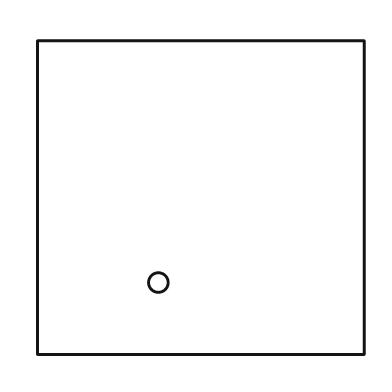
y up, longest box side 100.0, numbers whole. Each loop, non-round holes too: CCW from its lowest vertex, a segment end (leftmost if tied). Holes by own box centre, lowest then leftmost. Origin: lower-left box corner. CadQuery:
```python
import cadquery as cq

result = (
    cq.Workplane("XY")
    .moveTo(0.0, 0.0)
    .lineTo(100.0, 0.0)
    .lineTo(100.0, 96.0)
    .lineTo(0.0, 96.0)
    .close()
    .moveTo(37.0, 22.0)
    .circle(3.0)
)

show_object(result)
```